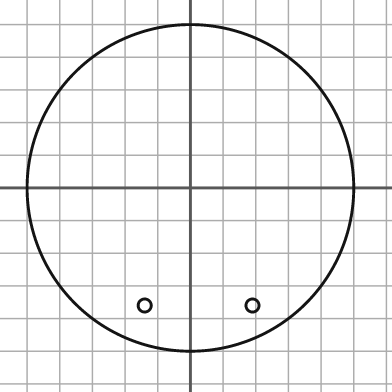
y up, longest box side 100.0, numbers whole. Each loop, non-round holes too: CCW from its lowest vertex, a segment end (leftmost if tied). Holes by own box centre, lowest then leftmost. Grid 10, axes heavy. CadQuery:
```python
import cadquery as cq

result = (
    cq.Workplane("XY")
    .moveTo(0.0, 0.0)
    .circle(50.0)
    .moveTo(-14.0, -36.0)
    .circle(2.0)
    .moveTo(19.0, -36.0)
    .circle(2.0)
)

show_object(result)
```